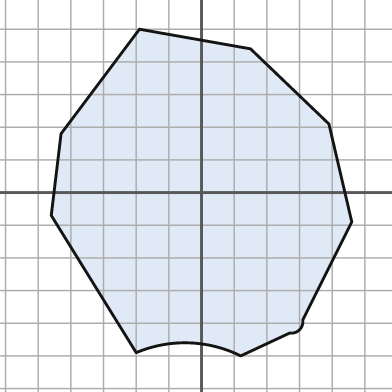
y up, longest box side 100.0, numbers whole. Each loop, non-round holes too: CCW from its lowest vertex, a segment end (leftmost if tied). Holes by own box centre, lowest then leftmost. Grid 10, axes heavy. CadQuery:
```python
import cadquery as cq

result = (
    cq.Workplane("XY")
    .moveTo(12.0, -50.0)
    .lineTo(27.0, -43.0)
    .threePointArc((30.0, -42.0), (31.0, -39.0))
    .lineTo(46.0, -9.0)
    .lineTo(39.0, 21.0)
    .lineTo(15.0, 44.0)
    .lineTo(-19.0, 50.0)
    .lineTo(-43.0, 18.0)
    .lineTo(-46.0, -7.0)
    .lineTo(-20.0, -49.0)
    .threePointArc((-4.0, -46.0), (12.0, -50.0))
    .close()
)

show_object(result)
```